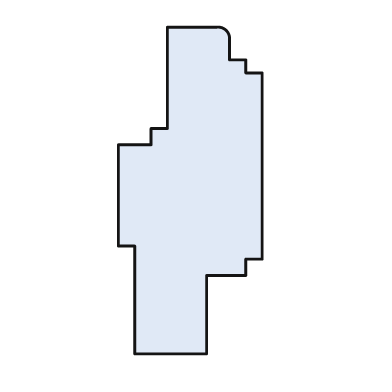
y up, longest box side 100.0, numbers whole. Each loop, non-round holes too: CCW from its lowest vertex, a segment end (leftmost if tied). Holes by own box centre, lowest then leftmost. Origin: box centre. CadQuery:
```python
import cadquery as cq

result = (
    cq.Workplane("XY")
    .moveTo(-17.0, -50.0)
    .lineTo(5.0, -50.0)
    .lineTo(5.0, -26.0)
    .lineTo(17.0, -26.0)
    .lineTo(17.0, -21.0)
    .lineTo(22.0, -21.0)
    .lineTo(22.0, 36.0)
    .lineTo(17.0, 36.0)
    .lineTo(17.0, 40.0)
    .lineTo(12.0, 40.0)
    .lineTo(12.0, 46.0)
    .threePointArc((11.0, 49.0), (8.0, 50.0))
    .lineTo(-7.0, 50.0)
    .lineTo(-7.0, 19.0)
    .lineTo(-12.0, 19.0)
    .lineTo(-12.0, 14.0)
    .lineTo(-22.0, 14.0)
    .lineTo(-22.0, -17.0)
    .lineTo(-17.0, -17.0)
    .close()
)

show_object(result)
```